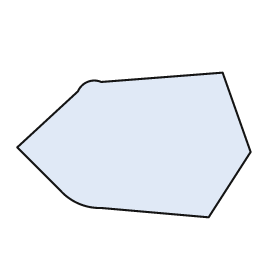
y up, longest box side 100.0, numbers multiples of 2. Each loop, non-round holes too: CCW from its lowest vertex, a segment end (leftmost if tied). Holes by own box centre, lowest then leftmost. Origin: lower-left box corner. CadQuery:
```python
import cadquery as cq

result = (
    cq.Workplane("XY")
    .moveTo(82.0, 0.0)
    .lineTo(100.0, 28.0)
    .lineTo(88.0, 62.0)
    .lineTo(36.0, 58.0)
    .threePointArc((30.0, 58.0), (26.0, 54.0))
    .lineTo(0.0, 30.0)
    .lineTo(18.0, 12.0)
    .threePointArc((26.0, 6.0), (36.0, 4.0))
    .close()
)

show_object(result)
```